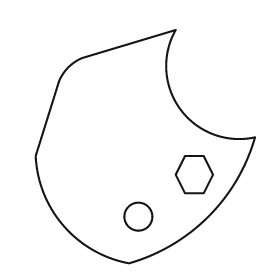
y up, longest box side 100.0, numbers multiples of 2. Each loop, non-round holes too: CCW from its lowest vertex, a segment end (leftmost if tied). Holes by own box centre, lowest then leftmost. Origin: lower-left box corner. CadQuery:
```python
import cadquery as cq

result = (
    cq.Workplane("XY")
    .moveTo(40.0, 0.0)
    .threePointArc((74.0, 20.0), (94.0, 54.0))
    .threePointArc((62.0, 66.0), (60.0, 100.0))
    .lineTo(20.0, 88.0)
    .threePointArc((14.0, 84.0), (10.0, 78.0))
    .lineTo(0.0, 46.0)
    .threePointArc((12.0, 16.0), (40.0, 0.0))
    .close()
    .moveTo(44.0, 20.0)
    .circle(6.0)
    .moveTo(64.0, 30.0)
    .lineTo(72.0, 30.0)
    .lineTo(76.0, 38.0)
    .lineTo(72.0, 46.0)
    .lineTo(64.0, 46.0)
    .lineTo(60.0, 38.0)
    .close()
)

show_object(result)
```